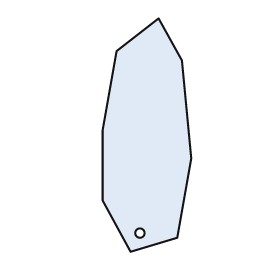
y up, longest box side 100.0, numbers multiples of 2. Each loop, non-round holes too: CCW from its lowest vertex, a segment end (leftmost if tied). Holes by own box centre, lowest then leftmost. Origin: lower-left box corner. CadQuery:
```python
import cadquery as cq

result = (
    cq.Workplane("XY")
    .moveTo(12.0, 0.0)
    .lineTo(32.0, 6.0)
    .lineTo(38.0, 40.0)
    .lineTo(34.0, 82.0)
    .lineTo(24.0, 100.0)
    .lineTo(6.0, 86.0)
    .lineTo(0.0, 52.0)
    .lineTo(0.0, 22.0)
    .close()
    .moveTo(16.0, 8.0)
    .circle(2.0)
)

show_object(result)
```